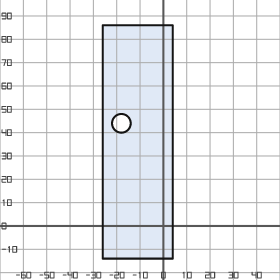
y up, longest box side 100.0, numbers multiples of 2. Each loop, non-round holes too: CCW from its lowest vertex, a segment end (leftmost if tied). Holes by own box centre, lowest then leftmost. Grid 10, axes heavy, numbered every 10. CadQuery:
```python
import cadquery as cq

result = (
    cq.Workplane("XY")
    .moveTo(-26.0, -14.0)
    .lineTo(4.0, -14.0)
    .lineTo(4.0, 86.0)
    .lineTo(-26.0, 86.0)
    .close()
    .moveTo(-18.0, 44.0)
    .circle(4.0)
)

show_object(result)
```